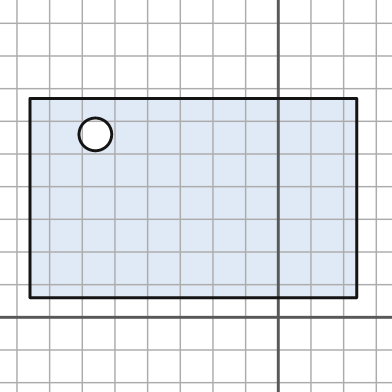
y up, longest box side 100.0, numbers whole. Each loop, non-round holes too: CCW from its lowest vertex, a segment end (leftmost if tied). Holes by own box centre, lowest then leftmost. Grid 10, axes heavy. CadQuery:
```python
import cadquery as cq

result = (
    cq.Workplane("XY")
    .moveTo(-76.0, 6.0)
    .lineTo(24.0, 6.0)
    .lineTo(24.0, 67.0)
    .lineTo(-76.0, 67.0)
    .close()
    .moveTo(-56.0, 56.0)
    .circle(5.0)
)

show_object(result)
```